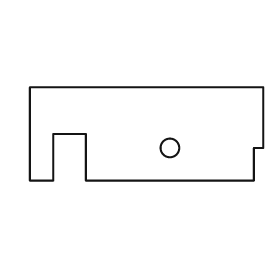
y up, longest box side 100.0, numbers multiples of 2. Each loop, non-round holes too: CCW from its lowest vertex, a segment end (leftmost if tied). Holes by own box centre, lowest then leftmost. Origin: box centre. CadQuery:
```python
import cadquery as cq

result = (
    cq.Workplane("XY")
    .moveTo(-50.0, -20.0)
    .lineTo(-40.0, -20.0)
    .lineTo(-40.0, 0.0)
    .lineTo(-26.0, 0.0)
    .lineTo(-26.0, -20.0)
    .lineTo(46.0, -20.0)
    .lineTo(46.0, -6.0)
    .lineTo(50.0, -6.0)
    .lineTo(50.0, 20.0)
    .lineTo(-50.0, 20.0)
    .close()
    .moveTo(10.0, -6.0)
    .circle(4.0)
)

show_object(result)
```